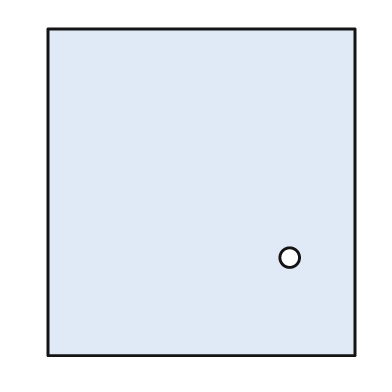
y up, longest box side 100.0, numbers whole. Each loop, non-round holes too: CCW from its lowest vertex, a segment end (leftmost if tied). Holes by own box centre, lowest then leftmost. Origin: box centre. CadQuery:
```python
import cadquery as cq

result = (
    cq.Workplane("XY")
    .moveTo(-47.0, -50.0)
    .lineTo(47.0, -50.0)
    .lineTo(47.0, 50.0)
    .lineTo(-47.0, 50.0)
    .close()
    .moveTo(27.0, -20.0)
    .circle(3.0)
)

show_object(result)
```